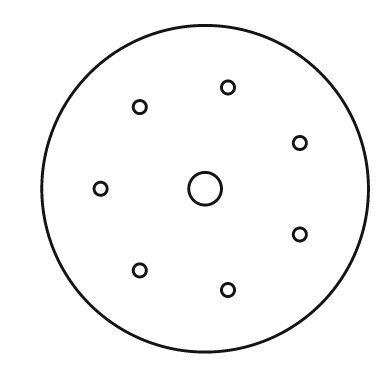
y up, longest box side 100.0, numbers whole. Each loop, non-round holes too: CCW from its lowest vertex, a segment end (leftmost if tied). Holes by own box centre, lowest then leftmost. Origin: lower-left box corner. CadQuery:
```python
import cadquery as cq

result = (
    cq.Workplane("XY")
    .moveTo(50.0, 50.0)
    .circle(50.0)
    .moveTo(57.0, 19.0)
    .circle(2.0)
    .moveTo(30.0, 25.0)
    .circle(2.0)
    .moveTo(79.0, 36.0)
    .circle(2.0)
    .moveTo(18.0, 50.0)
    .circle(2.0)
    .moveTo(50.0, 50.0)
    .circle(5.0)
    .moveTo(79.0, 64.0)
    .circle(2.0)
    .moveTo(30.0, 75.0)
    .circle(2.0)
    .moveTo(57.0, 81.0)
    .circle(2.0)
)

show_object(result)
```